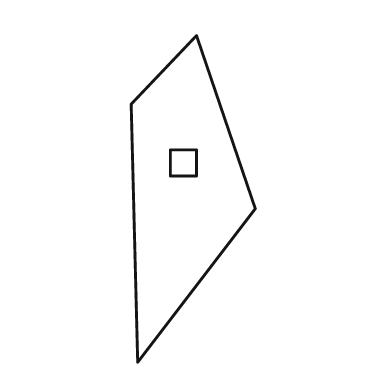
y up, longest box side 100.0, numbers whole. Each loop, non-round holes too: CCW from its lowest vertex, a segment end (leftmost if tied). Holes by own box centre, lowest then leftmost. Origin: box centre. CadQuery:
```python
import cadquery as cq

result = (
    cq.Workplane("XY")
    .moveTo(-17.0, -50.0)
    .lineTo(19.0, -3.0)
    .lineTo(1.0, 50.0)
    .lineTo(-19.0, 29.0)
    .close()
    .moveTo(-7.0, 7.0)
    .lineTo(1.0, 7.0)
    .lineTo(1.0, 15.0)
    .lineTo(-7.0, 15.0)
    .close()
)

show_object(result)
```